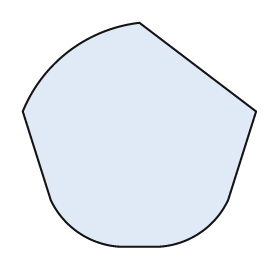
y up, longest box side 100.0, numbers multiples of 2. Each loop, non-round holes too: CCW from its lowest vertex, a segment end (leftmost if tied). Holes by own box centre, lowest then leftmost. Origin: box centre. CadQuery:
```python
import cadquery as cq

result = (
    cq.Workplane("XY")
    .moveTo(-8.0, -48.0)
    .lineTo(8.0, -48.0)
    .threePointArc((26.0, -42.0), (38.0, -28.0))
    .lineTo(50.0, 10.0)
    .lineTo(0.0, 48.0)
    .threePointArc((-30.0, 36.0), (-50.0, 10.0))
    .lineTo(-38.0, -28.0)
    .threePointArc((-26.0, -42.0), (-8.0, -48.0))
    .close()
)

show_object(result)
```